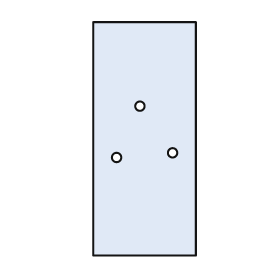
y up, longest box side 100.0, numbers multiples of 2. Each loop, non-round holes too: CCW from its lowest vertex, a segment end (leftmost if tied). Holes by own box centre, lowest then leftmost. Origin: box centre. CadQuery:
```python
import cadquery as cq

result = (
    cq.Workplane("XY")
    .moveTo(-22.0, -50.0)
    .lineTo(22.0, -50.0)
    .lineTo(22.0, 50.0)
    .lineTo(-22.0, 50.0)
    .close()
    .moveTo(-12.0, -8.0)
    .circle(2.0)
    .moveTo(12.0, -6.0)
    .circle(2.0)
    .moveTo(-2.0, 14.0)
    .circle(2.0)
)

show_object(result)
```